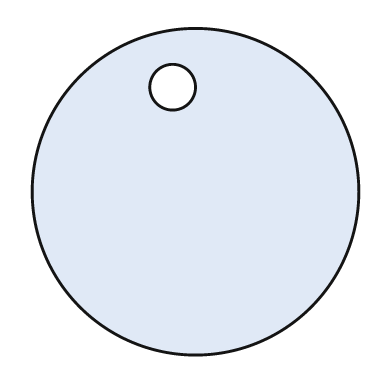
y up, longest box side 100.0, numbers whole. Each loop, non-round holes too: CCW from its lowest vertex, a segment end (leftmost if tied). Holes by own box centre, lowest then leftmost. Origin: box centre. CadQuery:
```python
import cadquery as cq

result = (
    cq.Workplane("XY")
    .moveTo(0.0, 0.0)
    .circle(50.0)
    .moveTo(-7.0, 32.0)
    .circle(7.0)
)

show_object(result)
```